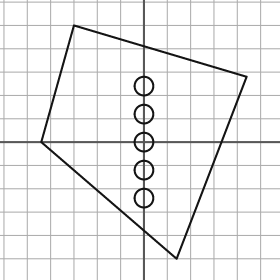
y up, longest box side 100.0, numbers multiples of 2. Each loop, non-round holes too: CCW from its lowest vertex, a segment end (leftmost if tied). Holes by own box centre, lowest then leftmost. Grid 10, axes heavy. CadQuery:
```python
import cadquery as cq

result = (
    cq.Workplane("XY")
    .moveTo(14.0, -50.0)
    .lineTo(44.0, 28.0)
    .lineTo(-30.0, 50.0)
    .lineTo(-44.0, 0.0)
    .close()
    .moveTo(0.0, -24.0)
    .circle(4.0)
    .moveTo(0.0, -12.0)
    .circle(4.0)
    .moveTo(0.0, 0.0)
    .circle(4.0)
    .moveTo(0.0, 12.0)
    .circle(4.0)
    .moveTo(0.0, 24.0)
    .circle(4.0)
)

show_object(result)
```